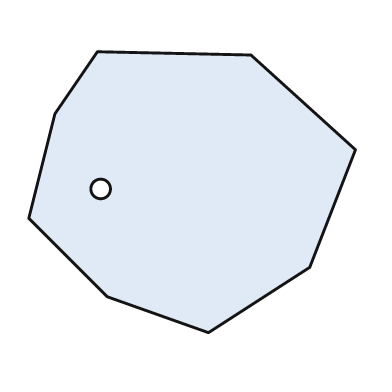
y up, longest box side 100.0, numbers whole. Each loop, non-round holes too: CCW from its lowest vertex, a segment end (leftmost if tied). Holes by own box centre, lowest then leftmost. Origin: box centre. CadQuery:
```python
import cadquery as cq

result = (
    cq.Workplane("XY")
    .moveTo(5.0, -43.0)
    .lineTo(36.0, -23.0)
    .lineTo(50.0, 13.0)
    .lineTo(18.0, 42.0)
    .lineTo(-29.0, 43.0)
    .lineTo(-42.0, 24.0)
    .lineTo(-50.0, -8.0)
    .lineTo(-26.0, -32.0)
    .close()
    .moveTo(-28.0, 1.0)
    .circle(3.0)
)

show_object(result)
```